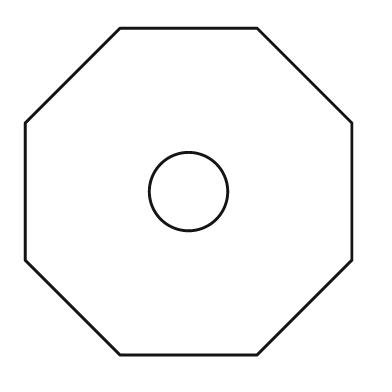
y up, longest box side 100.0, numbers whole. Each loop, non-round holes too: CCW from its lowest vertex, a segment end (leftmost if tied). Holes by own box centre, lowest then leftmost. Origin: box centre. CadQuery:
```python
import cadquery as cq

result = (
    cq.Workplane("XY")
    .moveTo(-21.0, -50.0)
    .lineTo(21.0, -50.0)
    .lineTo(50.0, -21.0)
    .lineTo(50.0, 21.0)
    .lineTo(21.0, 50.0)
    .lineTo(-21.0, 50.0)
    .lineTo(-50.0, 21.0)
    .lineTo(-50.0, -21.0)
    .close()
    .moveTo(0.0, 0.0)
    .circle(12.0)
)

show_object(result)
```